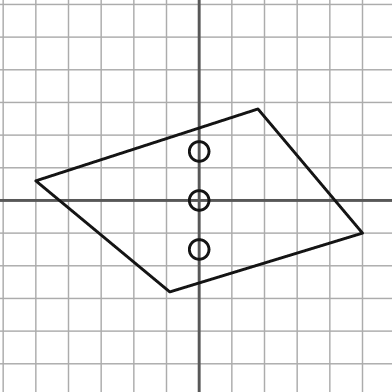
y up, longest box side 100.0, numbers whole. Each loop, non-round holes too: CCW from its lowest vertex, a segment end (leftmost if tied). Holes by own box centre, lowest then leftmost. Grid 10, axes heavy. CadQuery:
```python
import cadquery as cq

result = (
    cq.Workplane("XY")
    .moveTo(-9.0, -28.0)
    .lineTo(50.0, -10.0)
    .lineTo(18.0, 28.0)
    .lineTo(-50.0, 6.0)
    .close()
    .moveTo(0.0, -15.0)
    .circle(3.0)
    .moveTo(0.0, 0.0)
    .circle(3.0)
    .moveTo(0.0, 15.0)
    .circle(3.0)
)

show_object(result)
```